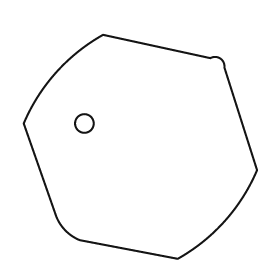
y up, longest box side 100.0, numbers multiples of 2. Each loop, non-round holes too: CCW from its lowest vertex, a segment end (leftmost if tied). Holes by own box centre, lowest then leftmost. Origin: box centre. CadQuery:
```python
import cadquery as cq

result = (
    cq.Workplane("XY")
    .moveTo(16.0, -48.0)
    .threePointArc((36.0, -32.0), (50.0, -10.0))
    .lineTo(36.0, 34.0)
    .threePointArc((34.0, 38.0), (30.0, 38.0))
    .lineTo(-16.0, 48.0)
    .threePointArc((-36.0, 32.0), (-50.0, 10.0))
    .lineTo(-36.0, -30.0)
    .threePointArc((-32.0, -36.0), (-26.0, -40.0))
    .close()
    .moveTo(-24.0, 10.0)
    .circle(4.0)
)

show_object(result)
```